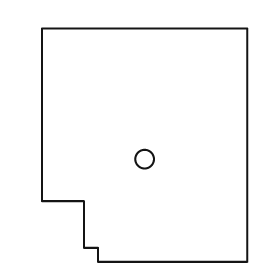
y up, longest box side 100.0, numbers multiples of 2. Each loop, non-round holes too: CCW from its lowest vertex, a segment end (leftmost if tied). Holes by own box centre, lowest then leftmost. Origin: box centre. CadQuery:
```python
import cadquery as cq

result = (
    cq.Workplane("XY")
    .moveTo(-20.0, -50.0)
    .lineTo(44.0, -50.0)
    .lineTo(44.0, 50.0)
    .lineTo(-44.0, 50.0)
    .lineTo(-44.0, -24.0)
    .lineTo(-26.0, -24.0)
    .lineTo(-26.0, -44.0)
    .lineTo(-20.0, -44.0)
    .close()
    .moveTo(0.0, -6.0)
    .circle(4.0)
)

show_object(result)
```